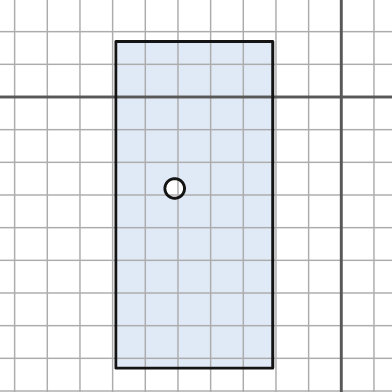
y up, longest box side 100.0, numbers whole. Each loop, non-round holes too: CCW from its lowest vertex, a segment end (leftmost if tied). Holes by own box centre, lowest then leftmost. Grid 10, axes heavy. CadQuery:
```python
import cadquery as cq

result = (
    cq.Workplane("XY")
    .moveTo(-69.0, -83.0)
    .lineTo(-21.0, -83.0)
    .lineTo(-21.0, 17.0)
    .lineTo(-69.0, 17.0)
    .close()
    .moveTo(-51.0, -28.0)
    .circle(3.0)
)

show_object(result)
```